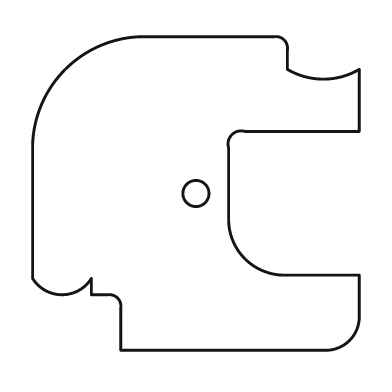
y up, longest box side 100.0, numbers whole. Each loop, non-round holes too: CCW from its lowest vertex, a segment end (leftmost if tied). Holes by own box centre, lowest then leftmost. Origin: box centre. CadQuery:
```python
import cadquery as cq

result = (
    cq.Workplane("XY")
    .moveTo(-23.0, -48.0)
    .lineTo(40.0, -48.0)
    .threePointArc((47.0, -45.0), (50.0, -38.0))
    .lineTo(50.0, -25.0)
    .lineTo(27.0, -25.0)
    .threePointArc((15.0, -20.0), (10.0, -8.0))
    .lineTo(10.0, 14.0)
    .threePointArc((11.0, 18.0), (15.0, 19.0))
    .lineTo(50.0, 19.0)
    .lineTo(50.0, 38.0)
    .threePointArc((39.0, 35.0), (28.0, 38.0))
    .lineTo(28.0, 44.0)
    .threePointArc((27.0, 47.0), (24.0, 48.0))
    .lineTo(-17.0, 48.0)
    .threePointArc((-40.0, 38.0), (-50.0, 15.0))
    .lineTo(-50.0, -26.0)
    .threePointArc((-41.0, -31.0), (-32.0, -26.0))
    .lineTo(-32.0, -31.0)
    .lineTo(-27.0, -31.0)
    .threePointArc((-24.0, -32.0), (-23.0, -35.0))
    .close()
    .moveTo(0.0, 0.0)
    .circle(4.0)
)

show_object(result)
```